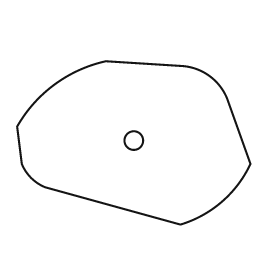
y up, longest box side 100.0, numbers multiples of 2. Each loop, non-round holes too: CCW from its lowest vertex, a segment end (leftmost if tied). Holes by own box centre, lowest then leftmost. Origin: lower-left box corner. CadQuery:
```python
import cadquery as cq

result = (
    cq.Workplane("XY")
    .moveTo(70.0, 0.0)
    .threePointArc((88.0, 10.0), (100.0, 26.0))
    .lineTo(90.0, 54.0)
    .threePointArc((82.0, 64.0), (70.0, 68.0))
    .lineTo(38.0, 70.0)
    .threePointArc((16.0, 60.0), (0.0, 42.0))
    .lineTo(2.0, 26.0)
    .threePointArc((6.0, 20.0), (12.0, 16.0))
    .close()
    .moveTo(50.0, 36.0)
    .circle(4.0)
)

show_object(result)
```